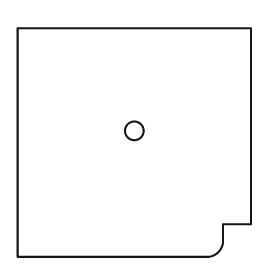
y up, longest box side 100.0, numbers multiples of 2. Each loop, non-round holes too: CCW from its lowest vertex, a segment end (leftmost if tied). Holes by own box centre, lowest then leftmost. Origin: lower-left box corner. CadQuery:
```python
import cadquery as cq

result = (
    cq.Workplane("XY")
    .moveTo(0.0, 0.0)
    .lineTo(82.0, 0.0)
    .threePointArc((86.0, 2.0), (88.0, 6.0))
    .lineTo(88.0, 14.0)
    .lineTo(100.0, 14.0)
    .lineTo(100.0, 98.0)
    .lineTo(0.0, 98.0)
    .close()
    .moveTo(50.0, 54.0)
    .circle(4.0)
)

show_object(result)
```